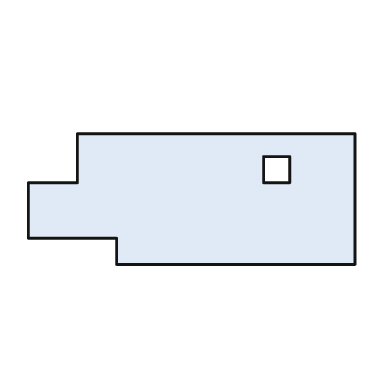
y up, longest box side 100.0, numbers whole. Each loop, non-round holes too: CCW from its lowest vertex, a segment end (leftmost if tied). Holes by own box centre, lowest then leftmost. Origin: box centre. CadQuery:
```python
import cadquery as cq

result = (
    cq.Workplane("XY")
    .moveTo(-23.0, -20.0)
    .lineTo(50.0, -20.0)
    .lineTo(50.0, 20.0)
    .lineTo(-35.0, 20.0)
    .lineTo(-35.0, 5.0)
    .lineTo(-50.0, 5.0)
    .lineTo(-50.0, -12.0)
    .lineTo(-23.0, -12.0)
    .close()
    .moveTo(22.0, 5.0)
    .lineTo(30.0, 5.0)
    .lineTo(30.0, 13.0)
    .lineTo(22.0, 13.0)
    .close()
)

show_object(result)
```